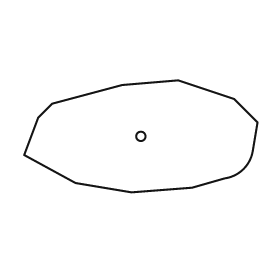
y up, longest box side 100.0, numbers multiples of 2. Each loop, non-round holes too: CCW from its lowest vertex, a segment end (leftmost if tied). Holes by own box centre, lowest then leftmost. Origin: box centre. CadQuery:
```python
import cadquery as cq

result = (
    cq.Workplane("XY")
    .moveTo(-4.0, -24.0)
    .lineTo(22.0, -22.0)
    .lineTo(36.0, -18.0)
    .threePointArc((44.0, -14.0), (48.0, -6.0))
    .lineTo(50.0, 6.0)
    .lineTo(40.0, 16.0)
    .lineTo(16.0, 24.0)
    .lineTo(-8.0, 22.0)
    .lineTo(-38.0, 14.0)
    .lineTo(-44.0, 8.0)
    .lineTo(-50.0, -8.0)
    .lineTo(-28.0, -20.0)
    .close()
    .moveTo(0.0, 0.0)
    .circle(2.0)
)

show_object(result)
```